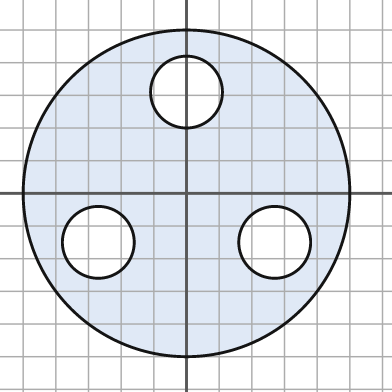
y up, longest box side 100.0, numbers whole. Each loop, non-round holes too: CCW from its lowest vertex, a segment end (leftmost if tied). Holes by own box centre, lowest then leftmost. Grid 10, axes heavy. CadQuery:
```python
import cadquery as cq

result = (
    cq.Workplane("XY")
    .moveTo(0.0, 0.0)
    .circle(50.0)
    .moveTo(-27.0, -15.0)
    .circle(11.0)
    .moveTo(27.0, -15.0)
    .circle(11.0)
    .moveTo(0.0, 31.0)
    .circle(11.0)
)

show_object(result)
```